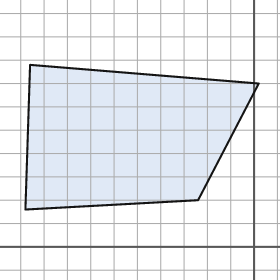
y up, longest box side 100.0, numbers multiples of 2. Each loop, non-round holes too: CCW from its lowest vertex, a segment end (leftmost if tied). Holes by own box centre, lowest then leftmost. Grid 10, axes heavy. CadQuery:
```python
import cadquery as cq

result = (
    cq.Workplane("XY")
    .moveTo(-98.0, 16.0)
    .lineTo(-24.0, 20.0)
    .lineTo(2.0, 70.0)
    .lineTo(-96.0, 78.0)
    .close()
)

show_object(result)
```